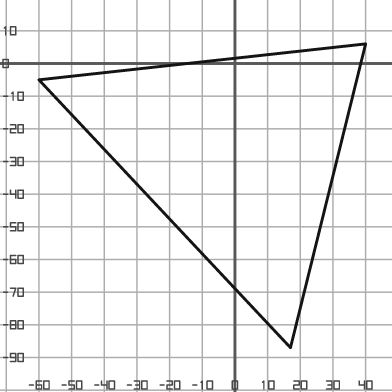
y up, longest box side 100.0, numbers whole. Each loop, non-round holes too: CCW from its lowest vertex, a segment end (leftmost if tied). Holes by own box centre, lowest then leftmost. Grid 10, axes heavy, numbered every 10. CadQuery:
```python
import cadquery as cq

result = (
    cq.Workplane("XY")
    .moveTo(17.0, -87.0)
    .lineTo(40.0, 6.0)
    .lineTo(-60.0, -5.0)
    .close()
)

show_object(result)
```